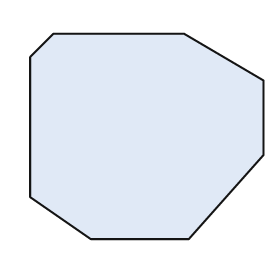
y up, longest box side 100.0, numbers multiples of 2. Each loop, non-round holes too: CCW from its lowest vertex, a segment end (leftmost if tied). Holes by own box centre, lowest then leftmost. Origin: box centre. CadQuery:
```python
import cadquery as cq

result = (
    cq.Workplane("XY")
    .moveTo(-24.0, -44.0)
    .lineTo(18.0, -44.0)
    .lineTo(50.0, -8.0)
    .lineTo(50.0, 24.0)
    .lineTo(16.0, 44.0)
    .lineTo(-40.0, 44.0)
    .lineTo(-50.0, 34.0)
    .lineTo(-50.0, -26.0)
    .close()
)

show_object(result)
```